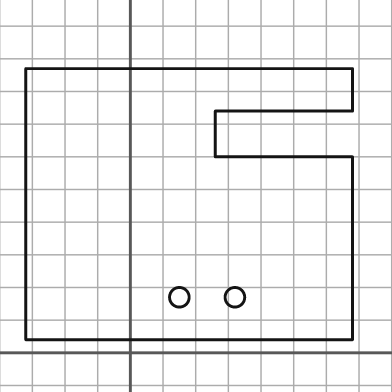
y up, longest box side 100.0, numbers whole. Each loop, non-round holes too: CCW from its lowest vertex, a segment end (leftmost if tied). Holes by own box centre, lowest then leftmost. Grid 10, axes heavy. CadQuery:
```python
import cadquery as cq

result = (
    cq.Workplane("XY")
    .moveTo(-32.0, 4.0)
    .lineTo(68.0, 4.0)
    .lineTo(68.0, 60.0)
    .lineTo(26.0, 60.0)
    .lineTo(26.0, 74.0)
    .lineTo(68.0, 74.0)
    .lineTo(68.0, 87.0)
    .lineTo(-32.0, 87.0)
    .close()
    .moveTo(15.0, 17.0)
    .circle(3.0)
    .moveTo(32.0, 17.0)
    .circle(3.0)
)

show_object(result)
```